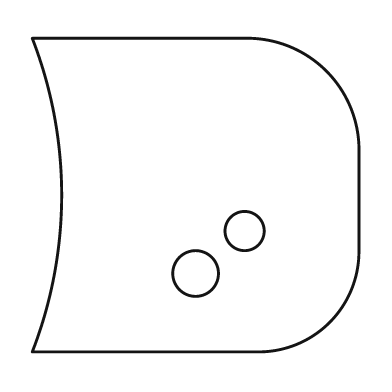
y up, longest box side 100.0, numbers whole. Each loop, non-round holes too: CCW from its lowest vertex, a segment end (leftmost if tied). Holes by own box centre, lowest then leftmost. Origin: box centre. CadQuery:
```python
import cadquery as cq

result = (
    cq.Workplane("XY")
    .moveTo(-50.0, -48.0)
    .lineTo(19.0, -48.0)
    .threePointArc((41.0, -39.0), (50.0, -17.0))
    .lineTo(50.0, 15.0)
    .threePointArc((40.0, 38.0), (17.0, 48.0))
    .lineTo(-50.0, 48.0)
    .threePointArc((-41.0, 0.0), (-50.0, -48.0))
    .close()
    .moveTo(0.0, -24.0)
    .circle(7.0)
    .moveTo(15.0, -11.0)
    .circle(6.0)
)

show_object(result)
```